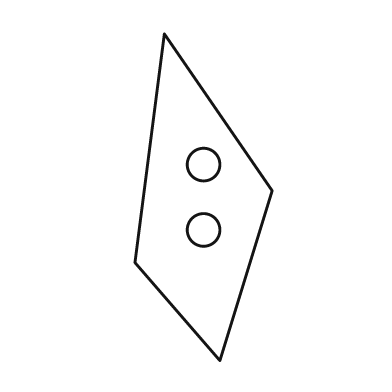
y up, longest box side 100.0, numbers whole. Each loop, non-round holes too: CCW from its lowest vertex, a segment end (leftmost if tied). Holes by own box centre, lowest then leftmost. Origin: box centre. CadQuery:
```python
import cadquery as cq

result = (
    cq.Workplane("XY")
    .moveTo(5.0, -50.0)
    .lineTo(21.0, 2.0)
    .lineTo(-12.0, 50.0)
    .lineTo(-21.0, -20.0)
    .close()
    .moveTo(0.0, -10.0)
    .circle(5.0)
    .moveTo(0.0, 10.0)
    .circle(5.0)
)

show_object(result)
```